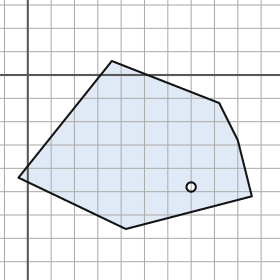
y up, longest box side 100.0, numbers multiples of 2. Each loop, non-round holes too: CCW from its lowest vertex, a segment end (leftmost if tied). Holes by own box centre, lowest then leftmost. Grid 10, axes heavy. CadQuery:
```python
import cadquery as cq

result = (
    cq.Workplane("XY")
    .moveTo(42.0, -66.0)
    .lineTo(96.0, -52.0)
    .lineTo(90.0, -28.0)
    .lineTo(82.0, -12.0)
    .lineTo(36.0, 6.0)
    .lineTo(-4.0, -44.0)
    .close()
    .moveTo(70.0, -48.0)
    .circle(2.0)
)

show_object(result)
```